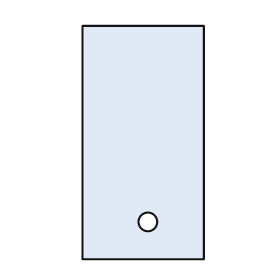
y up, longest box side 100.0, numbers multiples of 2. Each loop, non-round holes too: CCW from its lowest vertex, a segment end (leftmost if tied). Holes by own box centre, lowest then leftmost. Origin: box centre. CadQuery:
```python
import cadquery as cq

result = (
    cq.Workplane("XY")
    .moveTo(-26.0, -50.0)
    .lineTo(26.0, -50.0)
    .lineTo(26.0, 50.0)
    .lineTo(-26.0, 50.0)
    .close()
    .moveTo(2.0, -34.0)
    .circle(4.0)
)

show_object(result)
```